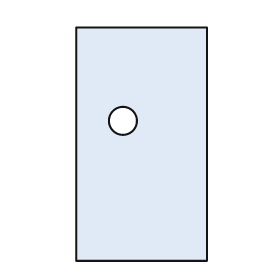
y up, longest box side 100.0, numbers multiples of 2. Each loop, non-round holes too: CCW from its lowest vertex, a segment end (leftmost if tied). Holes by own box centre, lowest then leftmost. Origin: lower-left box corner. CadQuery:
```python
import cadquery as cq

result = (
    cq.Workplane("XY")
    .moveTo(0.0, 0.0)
    .lineTo(56.0, 0.0)
    .lineTo(56.0, 100.0)
    .lineTo(0.0, 100.0)
    .close()
    .moveTo(20.0, 60.0)
    .circle(6.0)
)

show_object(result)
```